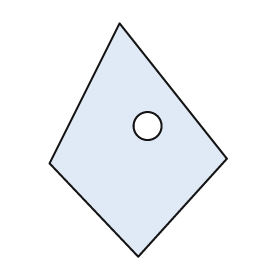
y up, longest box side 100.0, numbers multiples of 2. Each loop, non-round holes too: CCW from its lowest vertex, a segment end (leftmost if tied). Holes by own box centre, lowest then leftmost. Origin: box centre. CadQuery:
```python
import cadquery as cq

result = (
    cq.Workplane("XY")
    .moveTo(0.0, -50.0)
    .lineTo(38.0, -8.0)
    .lineTo(-8.0, 50.0)
    .lineTo(-38.0, -10.0)
    .close()
    .moveTo(4.0, 6.0)
    .circle(6.0)
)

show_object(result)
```